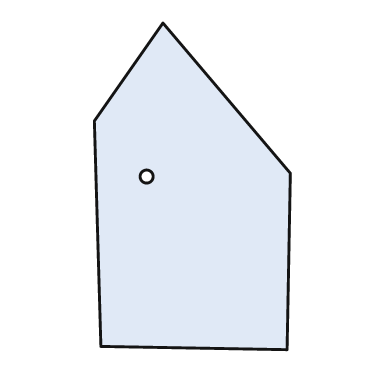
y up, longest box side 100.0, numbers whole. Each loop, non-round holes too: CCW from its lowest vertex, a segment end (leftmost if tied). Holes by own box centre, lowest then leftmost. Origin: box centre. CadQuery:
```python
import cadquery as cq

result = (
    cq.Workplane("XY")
    .moveTo(29.0, -50.0)
    .lineTo(30.0, 4.0)
    .lineTo(-9.0, 50.0)
    .lineTo(-30.0, 20.0)
    .lineTo(-28.0, -49.0)
    .close()
    .moveTo(-14.0, 3.0)
    .circle(2.0)
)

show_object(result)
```